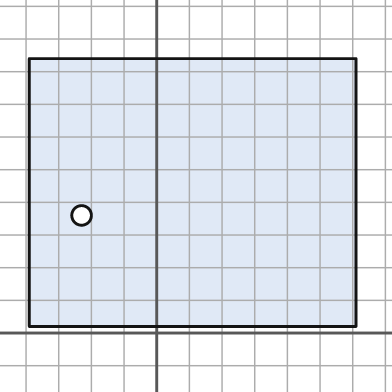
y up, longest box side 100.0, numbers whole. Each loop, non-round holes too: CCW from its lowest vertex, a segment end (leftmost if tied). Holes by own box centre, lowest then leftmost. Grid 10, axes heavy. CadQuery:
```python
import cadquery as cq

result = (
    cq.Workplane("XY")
    .moveTo(-39.0, 2.0)
    .lineTo(61.0, 2.0)
    .lineTo(61.0, 84.0)
    .lineTo(-39.0, 84.0)
    .close()
    .moveTo(-23.0, 36.0)
    .circle(3.0)
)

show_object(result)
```